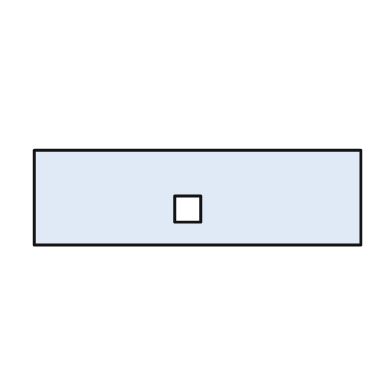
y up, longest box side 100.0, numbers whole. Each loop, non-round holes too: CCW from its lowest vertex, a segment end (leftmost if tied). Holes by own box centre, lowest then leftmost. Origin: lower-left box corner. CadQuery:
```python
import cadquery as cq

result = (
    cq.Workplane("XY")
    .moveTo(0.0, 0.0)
    .lineTo(100.0, 0.0)
    .lineTo(100.0, 29.0)
    .lineTo(0.0, 29.0)
    .close()
    .moveTo(43.0, 7.0)
    .lineTo(51.0, 7.0)
    .lineTo(51.0, 15.0)
    .lineTo(43.0, 15.0)
    .close()
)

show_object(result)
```